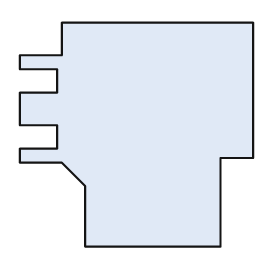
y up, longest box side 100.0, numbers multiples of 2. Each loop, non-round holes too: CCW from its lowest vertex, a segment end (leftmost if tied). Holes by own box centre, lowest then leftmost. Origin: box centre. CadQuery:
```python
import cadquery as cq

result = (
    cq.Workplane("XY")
    .moveTo(-22.0, -48.0)
    .lineTo(36.0, -48.0)
    .lineTo(36.0, -10.0)
    .lineTo(50.0, -10.0)
    .lineTo(50.0, 48.0)
    .lineTo(-32.0, 48.0)
    .lineTo(-32.0, 34.0)
    .lineTo(-50.0, 34.0)
    .lineTo(-50.0, 28.0)
    .lineTo(-34.0, 28.0)
    .lineTo(-34.0, 18.0)
    .lineTo(-50.0, 18.0)
    .lineTo(-50.0, 4.0)
    .lineTo(-34.0, 4.0)
    .lineTo(-34.0, -6.0)
    .lineTo(-50.0, -6.0)
    .lineTo(-50.0, -12.0)
    .lineTo(-32.0, -12.0)
    .lineTo(-22.0, -22.0)
    .close()
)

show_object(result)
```